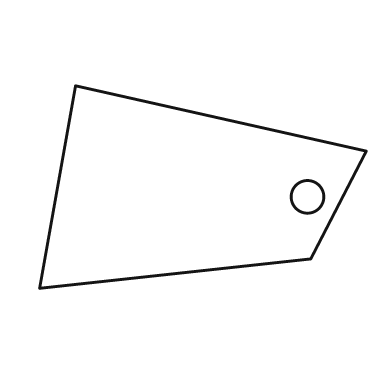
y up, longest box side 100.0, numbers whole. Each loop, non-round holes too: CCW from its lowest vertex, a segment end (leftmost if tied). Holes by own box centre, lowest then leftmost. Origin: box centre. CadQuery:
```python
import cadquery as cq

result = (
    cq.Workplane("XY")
    .moveTo(-50.0, -31.0)
    .lineTo(33.0, -22.0)
    .lineTo(50.0, 11.0)
    .lineTo(-39.0, 31.0)
    .close()
    .moveTo(32.0, -3.0)
    .circle(5.0)
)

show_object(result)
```